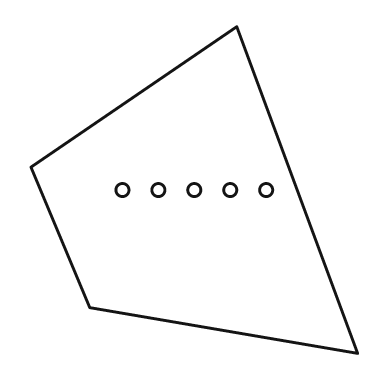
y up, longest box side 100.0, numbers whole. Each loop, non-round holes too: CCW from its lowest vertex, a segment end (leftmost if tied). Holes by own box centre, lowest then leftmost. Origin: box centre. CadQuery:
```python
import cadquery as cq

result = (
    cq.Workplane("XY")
    .moveTo(50.0, -50.0)
    .lineTo(13.0, 50.0)
    .lineTo(-50.0, 7.0)
    .lineTo(-32.0, -36.0)
    .close()
    .moveTo(-22.0, 0.0)
    .circle(2.0)
    .moveTo(-11.0, 0.0)
    .circle(2.0)
    .moveTo(0.0, 0.0)
    .circle(2.0)
    .moveTo(11.0, 0.0)
    .circle(2.0)
    .moveTo(22.0, 0.0)
    .circle(2.0)
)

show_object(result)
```